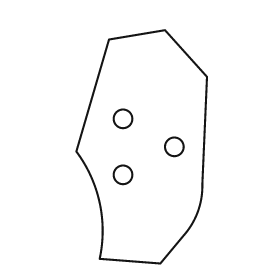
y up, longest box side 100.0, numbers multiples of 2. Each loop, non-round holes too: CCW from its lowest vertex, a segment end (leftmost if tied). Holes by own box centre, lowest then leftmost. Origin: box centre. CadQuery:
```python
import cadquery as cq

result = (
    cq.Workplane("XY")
    .moveTo(8.0, -50.0)
    .lineTo(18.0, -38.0)
    .threePointArc((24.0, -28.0), (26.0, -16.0))
    .lineTo(28.0, 30.0)
    .lineTo(10.0, 50.0)
    .lineTo(-14.0, 46.0)
    .lineTo(-28.0, -2.0)
    .threePointArc((-18.0, -24.0), (-18.0, -48.0))
    .close()
    .moveTo(-8.0, -12.0)
    .circle(4.0)
    .moveTo(14.0, 0.0)
    .circle(4.0)
    .moveTo(-8.0, 12.0)
    .circle(4.0)
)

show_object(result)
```